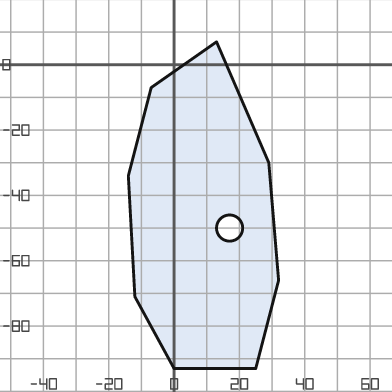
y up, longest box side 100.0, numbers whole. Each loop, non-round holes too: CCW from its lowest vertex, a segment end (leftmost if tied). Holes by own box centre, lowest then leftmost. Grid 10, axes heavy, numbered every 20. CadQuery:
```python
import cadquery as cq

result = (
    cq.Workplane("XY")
    .moveTo(0.0, -93.0)
    .lineTo(25.0, -93.0)
    .lineTo(32.0, -66.0)
    .lineTo(29.0, -30.0)
    .lineTo(13.0, 7.0)
    .lineTo(-7.0, -7.0)
    .lineTo(-14.0, -34.0)
    .lineTo(-12.0, -71.0)
    .close()
    .moveTo(17.0, -50.0)
    .circle(4.0)
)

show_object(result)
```